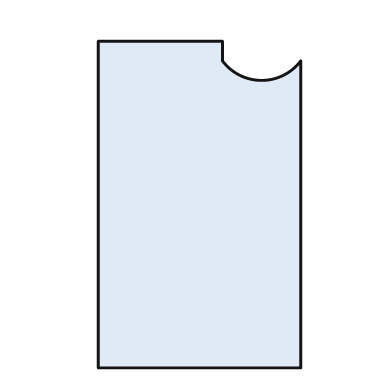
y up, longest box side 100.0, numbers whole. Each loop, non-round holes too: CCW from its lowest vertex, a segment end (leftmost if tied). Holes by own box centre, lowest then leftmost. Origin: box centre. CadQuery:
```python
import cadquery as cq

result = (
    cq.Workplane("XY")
    .moveTo(-31.0, -50.0)
    .lineTo(31.0, -50.0)
    .lineTo(31.0, 44.0)
    .threePointArc((19.0, 38.0), (7.0, 44.0))
    .lineTo(7.0, 50.0)
    .lineTo(-31.0, 50.0)
    .close()
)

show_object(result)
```